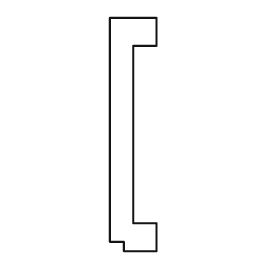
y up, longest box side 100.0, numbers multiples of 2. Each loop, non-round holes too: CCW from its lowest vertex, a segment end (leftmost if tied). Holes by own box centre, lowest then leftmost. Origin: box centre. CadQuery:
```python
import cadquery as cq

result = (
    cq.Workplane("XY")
    .moveTo(-4.0, -50.0)
    .lineTo(10.0, -50.0)
    .lineTo(10.0, -38.0)
    .lineTo(0.0, -38.0)
    .lineTo(0.0, 38.0)
    .lineTo(10.0, 38.0)
    .lineTo(10.0, 50.0)
    .lineTo(-10.0, 50.0)
    .lineTo(-10.0, -46.0)
    .lineTo(-4.0, -46.0)
    .close()
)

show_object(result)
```